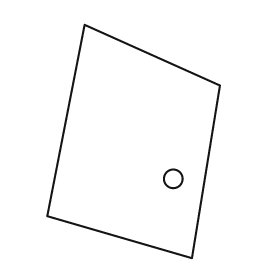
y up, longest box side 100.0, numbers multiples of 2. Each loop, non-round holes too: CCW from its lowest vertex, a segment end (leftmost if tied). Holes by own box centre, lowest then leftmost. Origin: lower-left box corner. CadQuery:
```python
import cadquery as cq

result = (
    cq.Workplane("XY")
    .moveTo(62.0, 0.0)
    .lineTo(74.0, 74.0)
    .lineTo(16.0, 100.0)
    .lineTo(0.0, 18.0)
    .close()
    .moveTo(54.0, 34.0)
    .circle(4.0)
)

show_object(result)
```